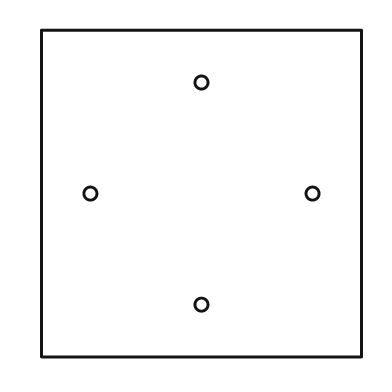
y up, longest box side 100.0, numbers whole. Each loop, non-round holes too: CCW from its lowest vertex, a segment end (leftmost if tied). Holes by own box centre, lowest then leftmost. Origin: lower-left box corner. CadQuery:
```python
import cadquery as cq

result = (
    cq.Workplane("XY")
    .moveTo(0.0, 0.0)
    .lineTo(98.0, 0.0)
    .lineTo(98.0, 100.0)
    .lineTo(0.0, 100.0)
    .close()
    .moveTo(49.0, 16.0)
    .circle(2.0)
    .moveTo(15.0, 50.0)
    .circle(2.0)
    .moveTo(83.0, 50.0)
    .circle(2.0)
    .moveTo(49.0, 84.0)
    .circle(2.0)
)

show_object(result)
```